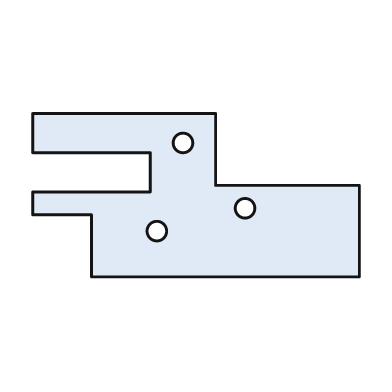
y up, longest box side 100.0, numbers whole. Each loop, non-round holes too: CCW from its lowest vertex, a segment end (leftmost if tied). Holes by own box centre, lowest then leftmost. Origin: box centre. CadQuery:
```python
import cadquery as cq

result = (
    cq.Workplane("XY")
    .moveTo(-32.0, -25.0)
    .lineTo(50.0, -25.0)
    .lineTo(50.0, 3.0)
    .lineTo(6.0, 3.0)
    .lineTo(6.0, 25.0)
    .lineTo(-50.0, 25.0)
    .lineTo(-50.0, 13.0)
    .lineTo(-14.0, 13.0)
    .lineTo(-14.0, 1.0)
    .lineTo(-50.0, 1.0)
    .lineTo(-50.0, -6.0)
    .lineTo(-32.0, -6.0)
    .close()
    .moveTo(-12.0, -11.0)
    .circle(3.0)
    .moveTo(15.0, -4.0)
    .circle(3.0)
    .moveTo(-4.0, 16.0)
    .circle(3.0)
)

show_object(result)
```